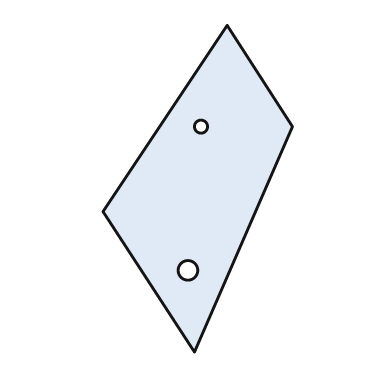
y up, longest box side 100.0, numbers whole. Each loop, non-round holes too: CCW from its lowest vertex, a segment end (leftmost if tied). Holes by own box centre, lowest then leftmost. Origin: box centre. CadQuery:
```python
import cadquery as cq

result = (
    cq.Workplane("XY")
    .moveTo(-1.0, -50.0)
    .lineTo(29.0, 19.0)
    .lineTo(9.0, 50.0)
    .lineTo(-29.0, -7.0)
    .close()
    .moveTo(-3.0, -25.0)
    .circle(3.0)
    .moveTo(1.0, 19.0)
    .circle(2.0)
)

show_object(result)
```